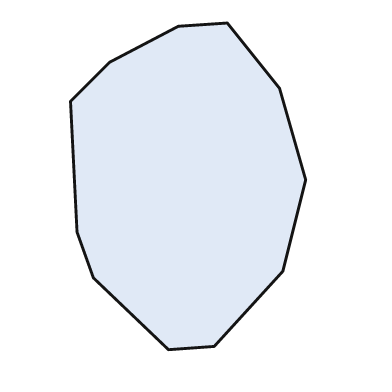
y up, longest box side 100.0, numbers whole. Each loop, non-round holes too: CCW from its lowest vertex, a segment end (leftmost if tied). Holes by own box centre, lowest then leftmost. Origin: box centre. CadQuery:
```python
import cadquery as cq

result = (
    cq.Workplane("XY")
    .moveTo(-6.0, -50.0)
    .lineTo(8.0, -49.0)
    .lineTo(29.0, -26.0)
    .lineTo(36.0, 2.0)
    .lineTo(28.0, 30.0)
    .lineTo(12.0, 50.0)
    .lineTo(-3.0, 49.0)
    .lineTo(-24.0, 38.0)
    .lineTo(-36.0, 26.0)
    .lineTo(-34.0, -14.0)
    .lineTo(-29.0, -28.0)
    .close()
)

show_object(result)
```